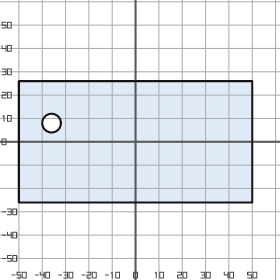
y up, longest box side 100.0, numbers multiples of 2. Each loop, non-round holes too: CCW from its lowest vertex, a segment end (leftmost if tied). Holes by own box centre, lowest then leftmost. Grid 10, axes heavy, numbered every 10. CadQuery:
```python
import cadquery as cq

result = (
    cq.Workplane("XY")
    .moveTo(-50.0, -26.0)
    .lineTo(50.0, -26.0)
    .lineTo(50.0, 26.0)
    .lineTo(-50.0, 26.0)
    .close()
    .moveTo(-36.0, 8.0)
    .circle(4.0)
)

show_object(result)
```